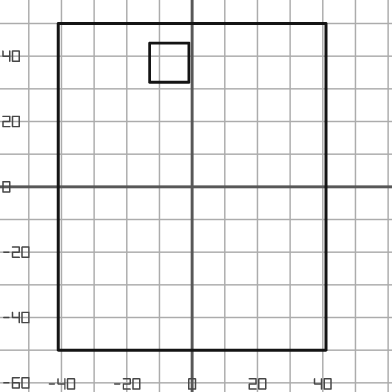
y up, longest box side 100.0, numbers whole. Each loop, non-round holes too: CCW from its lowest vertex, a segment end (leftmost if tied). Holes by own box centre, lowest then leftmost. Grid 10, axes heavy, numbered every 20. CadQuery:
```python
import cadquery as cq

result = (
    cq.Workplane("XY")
    .moveTo(-41.0, -50.0)
    .lineTo(41.0, -50.0)
    .lineTo(41.0, 50.0)
    .lineTo(-41.0, 50.0)
    .close()
    .moveTo(-13.0, 32.0)
    .lineTo(-1.0, 32.0)
    .lineTo(-1.0, 44.0)
    .lineTo(-13.0, 44.0)
    .close()
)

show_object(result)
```